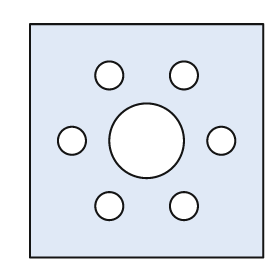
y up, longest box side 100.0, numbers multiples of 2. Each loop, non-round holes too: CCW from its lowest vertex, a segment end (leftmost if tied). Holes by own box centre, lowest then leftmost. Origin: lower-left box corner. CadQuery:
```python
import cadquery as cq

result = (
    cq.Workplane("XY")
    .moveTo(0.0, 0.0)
    .lineTo(100.0, 0.0)
    .lineTo(100.0, 100.0)
    .lineTo(0.0, 100.0)
    .close()
    .moveTo(34.0, 22.0)
    .circle(6.0)
    .moveTo(66.0, 22.0)
    .circle(6.0)
    .moveTo(18.0, 50.0)
    .circle(6.0)
    .moveTo(50.0, 50.0)
    .circle(16.0)
    .moveTo(82.0, 50.0)
    .circle(6.0)
    .moveTo(34.0, 78.0)
    .circle(6.0)
    .moveTo(66.0, 78.0)
    .circle(6.0)
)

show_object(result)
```